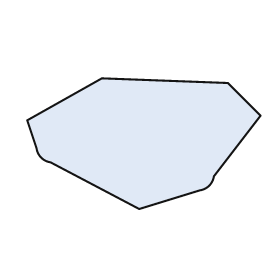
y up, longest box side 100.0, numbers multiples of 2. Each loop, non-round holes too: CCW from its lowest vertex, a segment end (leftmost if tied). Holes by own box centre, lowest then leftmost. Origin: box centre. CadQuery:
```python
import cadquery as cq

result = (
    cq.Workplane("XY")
    .moveTo(-2.0, -28.0)
    .lineTo(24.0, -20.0)
    .threePointArc((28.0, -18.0), (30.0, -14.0))
    .lineTo(50.0, 12.0)
    .lineTo(36.0, 26.0)
    .lineTo(-18.0, 28.0)
    .lineTo(-50.0, 10.0)
    .lineTo(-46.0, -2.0)
    .threePointArc((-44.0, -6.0), (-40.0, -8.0))
    .close()
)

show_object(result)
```